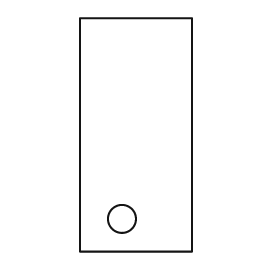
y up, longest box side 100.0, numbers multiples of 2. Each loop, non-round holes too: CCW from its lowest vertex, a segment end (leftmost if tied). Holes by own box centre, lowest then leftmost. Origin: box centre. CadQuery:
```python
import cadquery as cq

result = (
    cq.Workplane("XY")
    .moveTo(-24.0, -50.0)
    .lineTo(24.0, -50.0)
    .lineTo(24.0, 50.0)
    .lineTo(-24.0, 50.0)
    .close()
    .moveTo(-6.0, -36.0)
    .circle(6.0)
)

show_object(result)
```